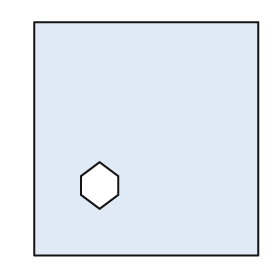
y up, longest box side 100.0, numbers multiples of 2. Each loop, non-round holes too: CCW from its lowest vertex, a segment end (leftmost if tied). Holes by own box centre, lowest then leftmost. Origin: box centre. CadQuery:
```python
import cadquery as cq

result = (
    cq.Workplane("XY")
    .moveTo(-48.0, -50.0)
    .lineTo(48.0, -50.0)
    .lineTo(48.0, 50.0)
    .lineTo(-48.0, 50.0)
    .close()
    .moveTo(-20.0, -30.0)
    .lineTo(-12.0, -24.0)
    .lineTo(-12.0, -16.0)
    .lineTo(-20.0, -10.0)
    .lineTo(-28.0, -16.0)
    .lineTo(-28.0, -24.0)
    .close()
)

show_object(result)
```